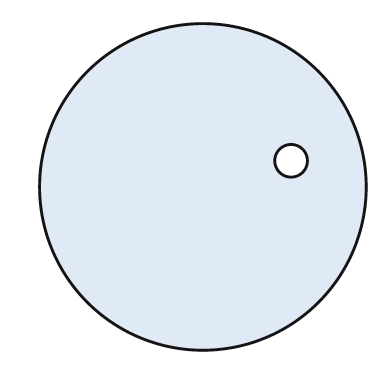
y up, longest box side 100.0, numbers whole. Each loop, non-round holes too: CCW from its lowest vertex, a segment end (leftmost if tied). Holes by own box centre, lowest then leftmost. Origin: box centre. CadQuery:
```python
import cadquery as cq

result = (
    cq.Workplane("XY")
    .moveTo(0.0, 0.0)
    .circle(50.0)
    .moveTo(27.0, 8.0)
    .circle(5.0)
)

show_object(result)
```